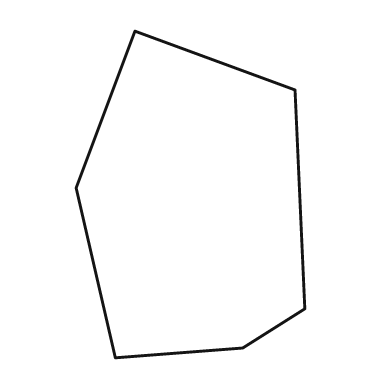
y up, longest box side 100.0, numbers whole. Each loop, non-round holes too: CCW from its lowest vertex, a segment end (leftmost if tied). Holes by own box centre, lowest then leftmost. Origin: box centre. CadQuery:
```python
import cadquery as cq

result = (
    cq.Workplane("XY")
    .moveTo(-23.0, -50.0)
    .lineTo(16.0, -47.0)
    .lineTo(35.0, -35.0)
    .lineTo(32.0, 32.0)
    .lineTo(-17.0, 50.0)
    .lineTo(-35.0, 2.0)
    .close()
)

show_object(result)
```